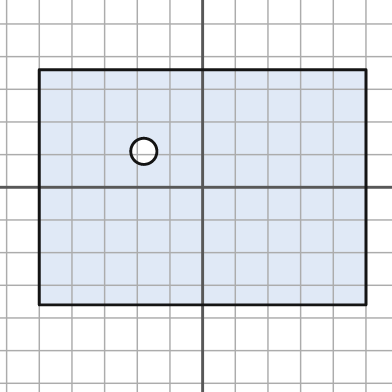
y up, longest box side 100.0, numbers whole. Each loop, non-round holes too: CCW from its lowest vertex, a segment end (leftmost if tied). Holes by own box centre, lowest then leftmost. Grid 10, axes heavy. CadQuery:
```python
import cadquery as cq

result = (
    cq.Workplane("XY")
    .moveTo(-50.0, -36.0)
    .lineTo(50.0, -36.0)
    .lineTo(50.0, 36.0)
    .lineTo(-50.0, 36.0)
    .close()
    .moveTo(-18.0, 11.0)
    .circle(4.0)
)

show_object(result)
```